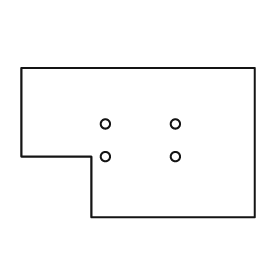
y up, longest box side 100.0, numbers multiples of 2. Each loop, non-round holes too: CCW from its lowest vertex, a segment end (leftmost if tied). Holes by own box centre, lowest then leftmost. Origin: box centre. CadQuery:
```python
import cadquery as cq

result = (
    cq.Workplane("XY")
    .moveTo(-20.0, -32.0)
    .lineTo(50.0, -32.0)
    .lineTo(50.0, 32.0)
    .lineTo(-50.0, 32.0)
    .lineTo(-50.0, -6.0)
    .lineTo(-20.0, -6.0)
    .close()
    .moveTo(-14.0, -6.0)
    .circle(2.0)
    .moveTo(16.0, -6.0)
    .circle(2.0)
    .moveTo(-14.0, 8.0)
    .circle(2.0)
    .moveTo(16.0, 8.0)
    .circle(2.0)
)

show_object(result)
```